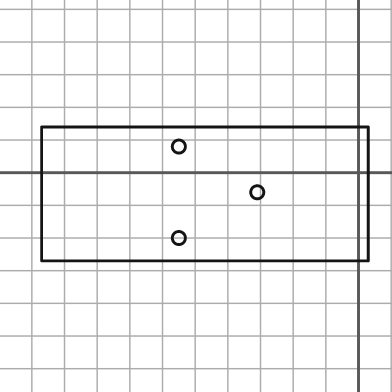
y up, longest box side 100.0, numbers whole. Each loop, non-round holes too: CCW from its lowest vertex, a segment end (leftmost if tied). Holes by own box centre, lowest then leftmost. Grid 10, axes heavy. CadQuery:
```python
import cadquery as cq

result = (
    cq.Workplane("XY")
    .moveTo(-97.0, -27.0)
    .lineTo(3.0, -27.0)
    .lineTo(3.0, 14.0)
    .lineTo(-97.0, 14.0)
    .close()
    .moveTo(-55.0, -20.0)
    .circle(2.0)
    .moveTo(-31.0, -6.0)
    .circle(2.0)
    .moveTo(-55.0, 8.0)
    .circle(2.0)
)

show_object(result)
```